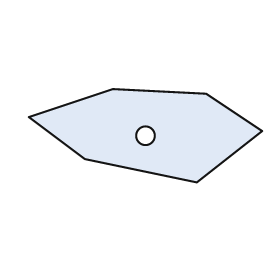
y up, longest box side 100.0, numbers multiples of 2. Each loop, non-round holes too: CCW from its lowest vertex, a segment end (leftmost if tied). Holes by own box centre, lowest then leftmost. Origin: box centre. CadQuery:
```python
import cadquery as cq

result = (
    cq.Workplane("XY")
    .moveTo(22.0, -20.0)
    .lineTo(50.0, 2.0)
    .lineTo(26.0, 18.0)
    .lineTo(-14.0, 20.0)
    .lineTo(-50.0, 8.0)
    .lineTo(-26.0, -10.0)
    .close()
    .moveTo(0.0, 0.0)
    .circle(4.0)
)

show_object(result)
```